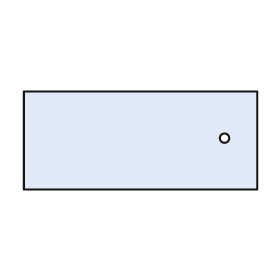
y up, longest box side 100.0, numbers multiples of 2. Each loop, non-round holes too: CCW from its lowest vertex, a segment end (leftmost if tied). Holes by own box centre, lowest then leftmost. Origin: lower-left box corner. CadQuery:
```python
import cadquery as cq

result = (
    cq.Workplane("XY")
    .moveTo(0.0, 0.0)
    .lineTo(100.0, 0.0)
    .lineTo(100.0, 42.0)
    .lineTo(0.0, 42.0)
    .close()
    .moveTo(86.0, 22.0)
    .circle(2.0)
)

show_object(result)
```